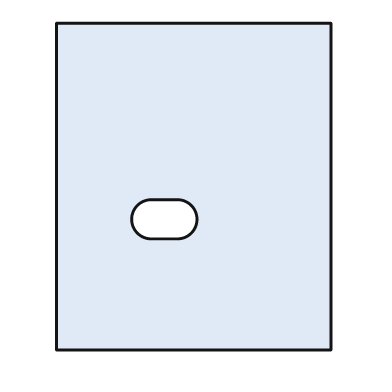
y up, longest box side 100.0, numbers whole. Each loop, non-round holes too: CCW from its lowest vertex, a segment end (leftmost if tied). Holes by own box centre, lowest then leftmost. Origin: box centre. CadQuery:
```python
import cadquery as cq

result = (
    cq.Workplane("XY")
    .moveTo(-42.0, -50.0)
    .lineTo(42.0, -50.0)
    .lineTo(42.0, 50.0)
    .lineTo(-42.0, 50.0)
    .close()
    .moveTo(-13.0, -16.0)
    .lineTo(-5.0, -16.0)
    .threePointArc((1.0, -10.0), (-5.0, -4.0))
    .lineTo(-13.0, -4.0)
    .threePointArc((-19.0, -10.0), (-13.0, -16.0))
    .close()
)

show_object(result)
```